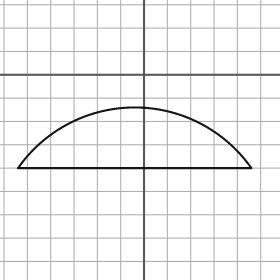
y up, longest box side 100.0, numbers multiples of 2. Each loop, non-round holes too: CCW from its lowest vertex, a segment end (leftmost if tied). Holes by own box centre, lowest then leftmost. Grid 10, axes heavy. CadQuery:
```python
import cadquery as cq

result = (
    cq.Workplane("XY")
    .moveTo(-54.0, -40.0)
    .lineTo(46.0, -40.0)
    .threePointArc((-4.0, -14.0), (-54.0, -40.0))
    .close()
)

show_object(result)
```